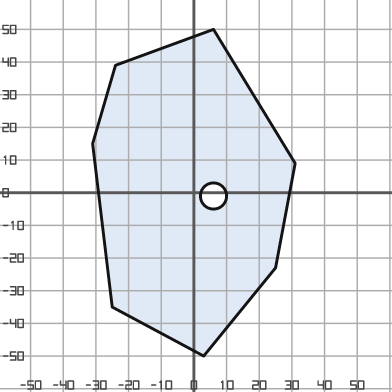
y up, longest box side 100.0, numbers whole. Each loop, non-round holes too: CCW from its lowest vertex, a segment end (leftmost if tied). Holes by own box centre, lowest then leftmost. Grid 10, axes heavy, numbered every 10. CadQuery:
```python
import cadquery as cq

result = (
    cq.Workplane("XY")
    .moveTo(3.0, -50.0)
    .lineTo(25.0, -23.0)
    .lineTo(31.0, 9.0)
    .lineTo(6.0, 50.0)
    .lineTo(-24.0, 39.0)
    .lineTo(-31.0, 15.0)
    .lineTo(-25.0, -35.0)
    .close()
    .moveTo(6.0, -1.0)
    .circle(4.0)
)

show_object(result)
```